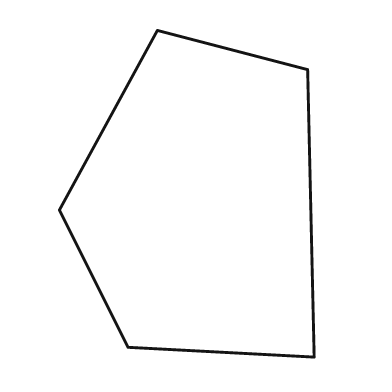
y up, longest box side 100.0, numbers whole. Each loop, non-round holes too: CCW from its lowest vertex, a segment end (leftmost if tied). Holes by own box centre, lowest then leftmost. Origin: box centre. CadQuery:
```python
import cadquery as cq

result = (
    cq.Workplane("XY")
    .moveTo(39.0, -50.0)
    .lineTo(37.0, 38.0)
    .lineTo(-9.0, 50.0)
    .lineTo(-39.0, -5.0)
    .lineTo(-18.0, -47.0)
    .close()
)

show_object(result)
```